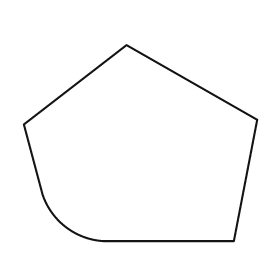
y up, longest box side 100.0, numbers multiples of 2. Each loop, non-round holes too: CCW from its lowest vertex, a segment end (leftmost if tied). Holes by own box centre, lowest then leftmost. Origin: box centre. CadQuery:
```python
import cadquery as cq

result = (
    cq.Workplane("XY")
    .moveTo(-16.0, -42.0)
    .lineTo(40.0, -42.0)
    .lineTo(50.0, 10.0)
    .lineTo(-6.0, 42.0)
    .lineTo(-50.0, 8.0)
    .lineTo(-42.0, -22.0)
    .threePointArc((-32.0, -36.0), (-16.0, -42.0))
    .close()
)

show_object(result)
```